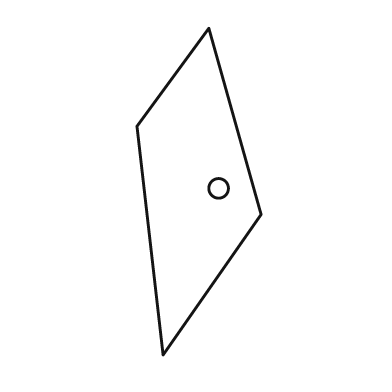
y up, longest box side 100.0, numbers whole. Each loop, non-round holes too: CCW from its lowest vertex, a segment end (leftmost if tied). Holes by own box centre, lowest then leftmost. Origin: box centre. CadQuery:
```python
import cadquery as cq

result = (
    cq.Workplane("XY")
    .moveTo(-11.0, -50.0)
    .lineTo(19.0, -7.0)
    .lineTo(3.0, 50.0)
    .lineTo(-19.0, 20.0)
    .close()
    .moveTo(6.0, 1.0)
    .circle(3.0)
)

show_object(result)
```